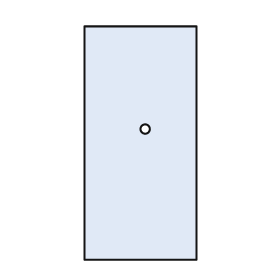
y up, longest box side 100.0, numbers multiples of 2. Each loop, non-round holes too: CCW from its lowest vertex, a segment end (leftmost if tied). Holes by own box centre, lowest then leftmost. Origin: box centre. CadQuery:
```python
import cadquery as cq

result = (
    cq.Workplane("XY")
    .moveTo(-24.0, -50.0)
    .lineTo(24.0, -50.0)
    .lineTo(24.0, 50.0)
    .lineTo(-24.0, 50.0)
    .close()
    .moveTo(2.0, 6.0)
    .circle(2.0)
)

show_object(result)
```